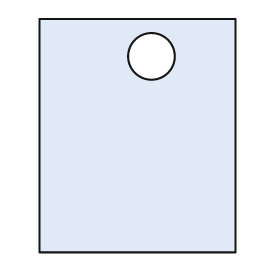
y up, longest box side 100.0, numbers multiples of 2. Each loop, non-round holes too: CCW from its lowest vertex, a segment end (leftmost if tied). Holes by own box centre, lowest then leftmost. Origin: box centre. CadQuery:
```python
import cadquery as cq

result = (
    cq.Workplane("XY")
    .moveTo(-42.0, -50.0)
    .lineTo(42.0, -50.0)
    .lineTo(42.0, 50.0)
    .lineTo(-42.0, 50.0)
    .close()
    .moveTo(6.0, 34.0)
    .circle(10.0)
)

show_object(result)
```